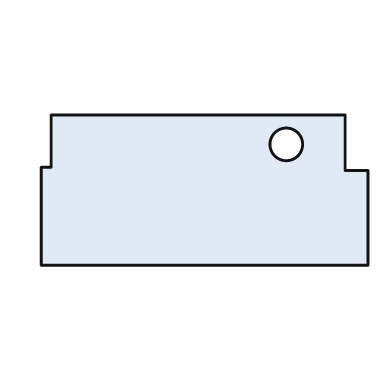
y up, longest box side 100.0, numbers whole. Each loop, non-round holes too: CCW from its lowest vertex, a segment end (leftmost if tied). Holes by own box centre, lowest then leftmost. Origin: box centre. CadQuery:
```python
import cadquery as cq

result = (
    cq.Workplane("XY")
    .moveTo(-50.0, -23.0)
    .lineTo(50.0, -23.0)
    .lineTo(50.0, 6.0)
    .lineTo(43.0, 6.0)
    .lineTo(43.0, 23.0)
    .lineTo(-47.0, 23.0)
    .lineTo(-47.0, 7.0)
    .lineTo(-50.0, 7.0)
    .close()
    .moveTo(25.0, 14.0)
    .circle(5.0)
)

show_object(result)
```